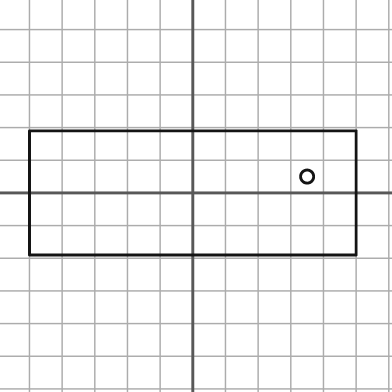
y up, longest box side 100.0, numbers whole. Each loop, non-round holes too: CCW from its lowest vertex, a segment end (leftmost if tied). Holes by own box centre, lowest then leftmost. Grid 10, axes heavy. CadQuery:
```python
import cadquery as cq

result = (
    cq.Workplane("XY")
    .moveTo(-50.0, -19.0)
    .lineTo(50.0, -19.0)
    .lineTo(50.0, 19.0)
    .lineTo(-50.0, 19.0)
    .close()
    .moveTo(35.0, 5.0)
    .circle(2.0)
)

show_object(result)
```